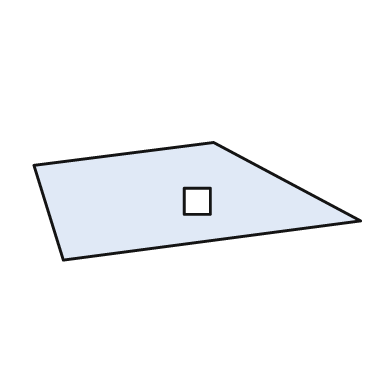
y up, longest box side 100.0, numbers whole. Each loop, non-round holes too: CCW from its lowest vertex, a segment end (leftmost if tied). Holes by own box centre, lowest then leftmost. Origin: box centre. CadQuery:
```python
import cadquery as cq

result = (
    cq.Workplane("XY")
    .moveTo(-41.0, -18.0)
    .lineTo(50.0, -6.0)
    .lineTo(5.0, 18.0)
    .lineTo(-50.0, 11.0)
    .close()
    .moveTo(-4.0, -4.0)
    .lineTo(4.0, -4.0)
    .lineTo(4.0, 4.0)
    .lineTo(-4.0, 4.0)
    .close()
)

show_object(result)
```